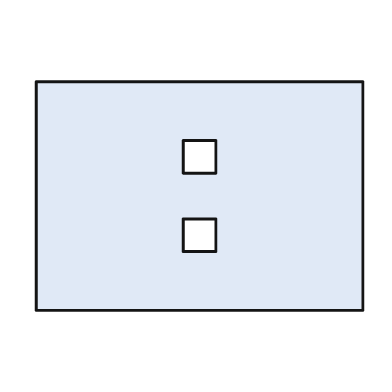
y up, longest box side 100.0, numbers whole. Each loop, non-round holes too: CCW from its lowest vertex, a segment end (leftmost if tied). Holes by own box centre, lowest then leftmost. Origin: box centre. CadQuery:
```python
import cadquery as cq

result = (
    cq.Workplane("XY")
    .moveTo(-50.0, -35.0)
    .lineTo(50.0, -35.0)
    .lineTo(50.0, 35.0)
    .lineTo(-50.0, 35.0)
    .close()
    .moveTo(-5.0, -17.0)
    .lineTo(5.0, -17.0)
    .lineTo(5.0, -7.0)
    .lineTo(-5.0, -7.0)
    .close()
    .moveTo(-5.0, 7.0)
    .lineTo(5.0, 7.0)
    .lineTo(5.0, 17.0)
    .lineTo(-5.0, 17.0)
    .close()
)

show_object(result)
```